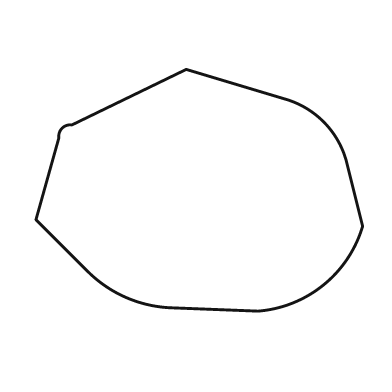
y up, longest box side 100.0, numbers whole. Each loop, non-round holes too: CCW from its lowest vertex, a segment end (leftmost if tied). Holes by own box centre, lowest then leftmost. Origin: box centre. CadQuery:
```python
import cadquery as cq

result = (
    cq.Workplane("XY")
    .moveTo(18.0, -37.0)
    .threePointArc((38.0, -29.0), (50.0, -11.0))
    .lineTo(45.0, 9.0)
    .threePointArc((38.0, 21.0), (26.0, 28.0))
    .lineTo(-4.0, 37.0)
    .lineTo(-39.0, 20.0)
    .threePointArc((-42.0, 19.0), (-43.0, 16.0))
    .lineTo(-50.0, -9.0)
    .lineTo(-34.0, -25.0)
    .threePointArc((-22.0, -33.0), (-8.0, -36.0))
    .close()
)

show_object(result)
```